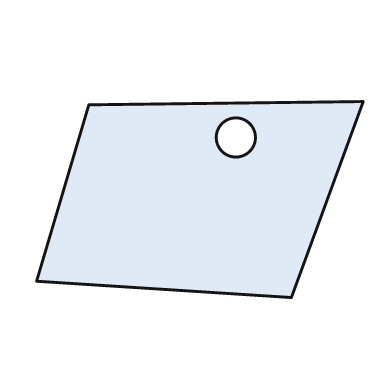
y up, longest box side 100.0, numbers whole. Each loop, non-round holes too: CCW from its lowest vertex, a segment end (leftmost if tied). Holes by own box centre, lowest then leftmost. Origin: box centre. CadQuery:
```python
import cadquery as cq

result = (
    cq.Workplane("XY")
    .moveTo(28.0, -30.0)
    .lineTo(50.0, 30.0)
    .lineTo(-34.0, 29.0)
    .lineTo(-50.0, -25.0)
    .close()
    .moveTo(11.0, 19.0)
    .circle(6.0)
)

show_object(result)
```